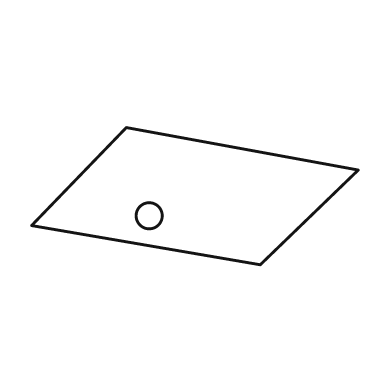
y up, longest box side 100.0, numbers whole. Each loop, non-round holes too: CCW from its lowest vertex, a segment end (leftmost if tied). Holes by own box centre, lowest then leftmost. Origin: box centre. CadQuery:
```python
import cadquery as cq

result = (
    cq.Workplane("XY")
    .moveTo(20.0, -21.0)
    .lineTo(50.0, 8.0)
    .lineTo(-21.0, 21.0)
    .lineTo(-50.0, -9.0)
    .close()
    .moveTo(-14.0, -6.0)
    .circle(4.0)
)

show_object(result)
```